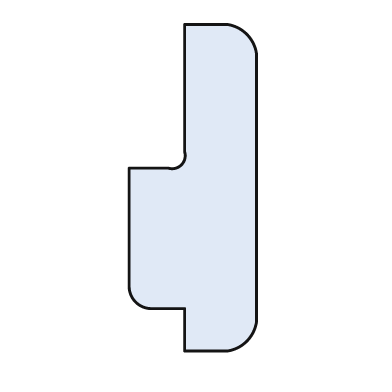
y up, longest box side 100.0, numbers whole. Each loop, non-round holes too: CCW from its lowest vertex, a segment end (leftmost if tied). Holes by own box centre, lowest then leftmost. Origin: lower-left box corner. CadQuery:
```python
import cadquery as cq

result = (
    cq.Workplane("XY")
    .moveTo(17.0, 0.0)
    .lineTo(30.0, 0.0)
    .threePointArc((36.0, 3.0), (39.0, 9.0))
    .lineTo(39.0, 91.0)
    .threePointArc((36.0, 97.0), (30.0, 100.0))
    .lineTo(17.0, 100.0)
    .lineTo(17.0, 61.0)
    .threePointArc((16.0, 57.0), (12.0, 56.0))
    .lineTo(0.0, 56.0)
    .lineTo(0.0, 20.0)
    .threePointArc((2.0, 15.0), (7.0, 13.0))
    .lineTo(17.0, 13.0)
    .close()
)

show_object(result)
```